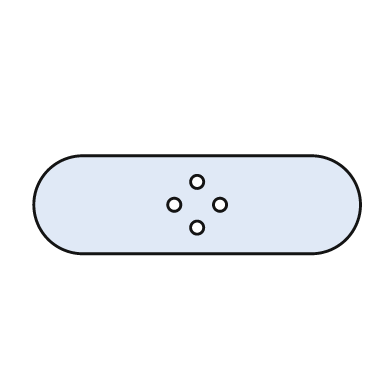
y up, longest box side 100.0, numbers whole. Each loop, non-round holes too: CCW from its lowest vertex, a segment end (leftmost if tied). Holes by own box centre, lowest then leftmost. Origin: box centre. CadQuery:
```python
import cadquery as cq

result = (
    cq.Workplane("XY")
    .moveTo(-35.0, -15.0)
    .lineTo(35.0, -15.0)
    .threePointArc((50.0, 0.0), (35.0, 15.0))
    .lineTo(-35.0, 15.0)
    .threePointArc((-50.0, 0.0), (-35.0, -15.0))
    .close()
    .moveTo(0.0, -7.0)
    .circle(2.0)
    .moveTo(-7.0, 0.0)
    .circle(2.0)
    .moveTo(7.0, 0.0)
    .circle(2.0)
    .moveTo(0.0, 7.0)
    .circle(2.0)
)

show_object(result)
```